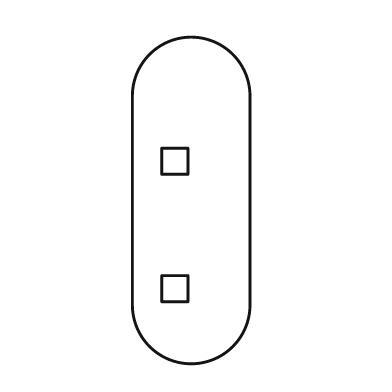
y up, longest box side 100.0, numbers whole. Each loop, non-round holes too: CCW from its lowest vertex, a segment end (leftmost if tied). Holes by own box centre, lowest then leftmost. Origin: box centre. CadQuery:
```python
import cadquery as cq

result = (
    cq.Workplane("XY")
    .moveTo(-18.0, -32.0)
    .threePointArc((0.0, -50.0), (18.0, -32.0))
    .lineTo(18.0, 32.0)
    .threePointArc((0.0, 50.0), (-18.0, 32.0))
    .close()
    .moveTo(-9.0, -31.0)
    .lineTo(-1.0, -31.0)
    .lineTo(-1.0, -23.0)
    .lineTo(-9.0, -23.0)
    .close()
    .moveTo(-9.0, 8.0)
    .lineTo(-1.0, 8.0)
    .lineTo(-1.0, 16.0)
    .lineTo(-9.0, 16.0)
    .close()
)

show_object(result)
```